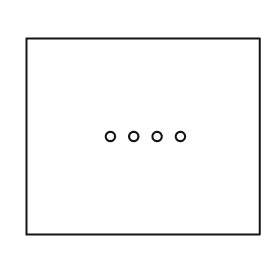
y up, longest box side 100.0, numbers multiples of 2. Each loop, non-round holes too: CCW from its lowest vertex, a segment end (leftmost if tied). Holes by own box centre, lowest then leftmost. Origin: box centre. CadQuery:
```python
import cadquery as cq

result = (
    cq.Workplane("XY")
    .moveTo(-50.0, -42.0)
    .lineTo(50.0, -42.0)
    .lineTo(50.0, 42.0)
    .lineTo(-50.0, 42.0)
    .close()
    .moveTo(-14.0, 0.0)
    .circle(2.0)
    .moveTo(-4.0, 0.0)
    .circle(2.0)
    .moveTo(6.0, 0.0)
    .circle(2.0)
    .moveTo(16.0, 0.0)
    .circle(2.0)
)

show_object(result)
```